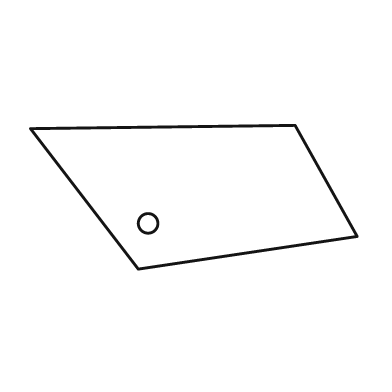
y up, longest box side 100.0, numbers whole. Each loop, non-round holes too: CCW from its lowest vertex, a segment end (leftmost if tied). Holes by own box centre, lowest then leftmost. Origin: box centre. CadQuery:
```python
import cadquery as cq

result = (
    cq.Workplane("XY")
    .moveTo(-17.0, -22.0)
    .lineTo(50.0, -12.0)
    .lineTo(31.0, 22.0)
    .lineTo(-50.0, 21.0)
    .close()
    .moveTo(-14.0, -8.0)
    .circle(3.0)
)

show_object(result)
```